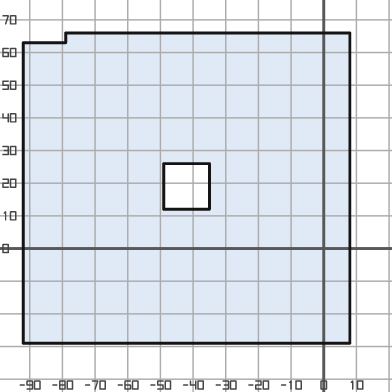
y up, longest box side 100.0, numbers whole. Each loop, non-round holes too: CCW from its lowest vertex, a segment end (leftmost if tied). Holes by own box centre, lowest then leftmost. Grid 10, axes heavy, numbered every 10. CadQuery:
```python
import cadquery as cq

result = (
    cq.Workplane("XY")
    .moveTo(-92.0, -29.0)
    .lineTo(8.0, -29.0)
    .lineTo(8.0, 66.0)
    .lineTo(-79.0, 66.0)
    .lineTo(-79.0, 63.0)
    .lineTo(-92.0, 63.0)
    .close()
    .moveTo(-49.0, 12.0)
    .lineTo(-35.0, 12.0)
    .lineTo(-35.0, 26.0)
    .lineTo(-49.0, 26.0)
    .close()
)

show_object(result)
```